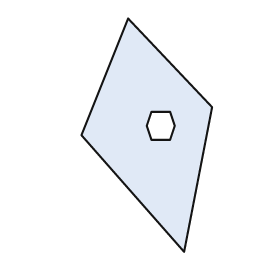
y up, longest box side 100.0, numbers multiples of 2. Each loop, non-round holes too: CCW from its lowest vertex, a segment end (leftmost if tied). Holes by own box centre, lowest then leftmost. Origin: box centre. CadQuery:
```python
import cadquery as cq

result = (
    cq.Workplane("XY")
    .moveTo(16.0, -50.0)
    .lineTo(28.0, 12.0)
    .lineTo(-8.0, 50.0)
    .lineTo(-28.0, 0.0)
    .close()
    .moveTo(2.0, -2.0)
    .lineTo(10.0, -2.0)
    .lineTo(12.0, 4.0)
    .lineTo(10.0, 10.0)
    .lineTo(2.0, 10.0)
    .lineTo(0.0, 4.0)
    .close()
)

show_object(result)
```